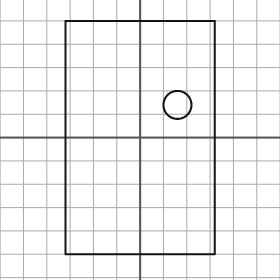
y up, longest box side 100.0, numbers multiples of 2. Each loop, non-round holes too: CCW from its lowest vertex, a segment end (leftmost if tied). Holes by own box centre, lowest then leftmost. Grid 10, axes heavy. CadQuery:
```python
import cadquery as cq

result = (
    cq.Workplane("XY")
    .moveTo(-32.0, -50.0)
    .lineTo(32.0, -50.0)
    .lineTo(32.0, 50.0)
    .lineTo(-32.0, 50.0)
    .close()
    .moveTo(16.0, 14.0)
    .circle(6.0)
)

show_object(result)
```